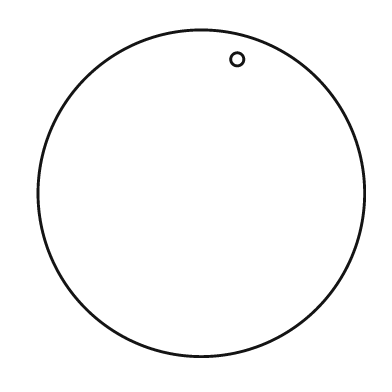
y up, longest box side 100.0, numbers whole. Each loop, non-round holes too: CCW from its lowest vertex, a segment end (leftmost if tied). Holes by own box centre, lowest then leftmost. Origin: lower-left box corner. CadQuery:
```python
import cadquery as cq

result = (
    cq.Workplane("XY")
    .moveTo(50.0, 50.0)
    .circle(50.0)
    .moveTo(61.0, 91.0)
    .circle(2.0)
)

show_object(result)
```